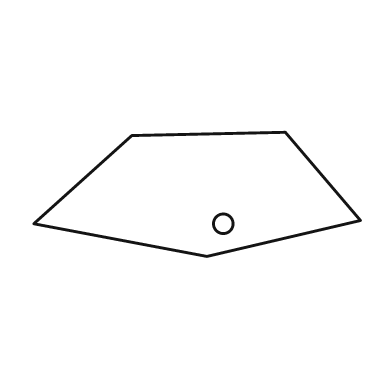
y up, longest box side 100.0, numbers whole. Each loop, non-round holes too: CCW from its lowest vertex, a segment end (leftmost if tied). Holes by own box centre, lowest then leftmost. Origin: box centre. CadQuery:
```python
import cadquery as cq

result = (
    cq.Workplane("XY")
    .moveTo(3.0, -19.0)
    .lineTo(50.0, -8.0)
    .lineTo(27.0, 19.0)
    .lineTo(-20.0, 18.0)
    .lineTo(-50.0, -9.0)
    .close()
    .moveTo(8.0, -9.0)
    .circle(3.0)
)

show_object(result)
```